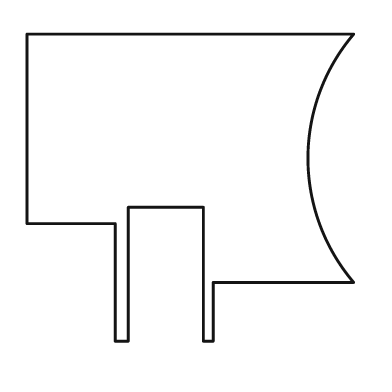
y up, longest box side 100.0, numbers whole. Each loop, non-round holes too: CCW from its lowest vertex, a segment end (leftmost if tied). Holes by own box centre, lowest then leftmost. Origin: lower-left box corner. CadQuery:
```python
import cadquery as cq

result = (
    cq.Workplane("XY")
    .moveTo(27.0, 0.0)
    .lineTo(31.0, 0.0)
    .lineTo(31.0, 41.0)
    .lineTo(54.0, 41.0)
    .lineTo(54.0, 0.0)
    .lineTo(57.0, 0.0)
    .lineTo(57.0, 18.0)
    .lineTo(100.0, 18.0)
    .threePointArc((86.0, 56.0), (100.0, 94.0))
    .lineTo(0.0, 94.0)
    .lineTo(0.0, 36.0)
    .lineTo(27.0, 36.0)
    .close()
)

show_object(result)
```